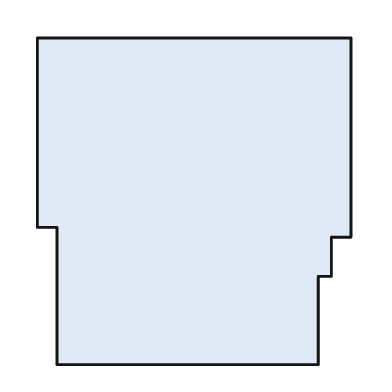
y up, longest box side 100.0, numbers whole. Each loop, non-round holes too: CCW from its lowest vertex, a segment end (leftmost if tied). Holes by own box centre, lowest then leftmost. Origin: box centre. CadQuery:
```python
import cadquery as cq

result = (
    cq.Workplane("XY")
    .moveTo(-42.0, -50.0)
    .lineTo(38.0, -50.0)
    .lineTo(38.0, -23.0)
    .lineTo(42.0, -23.0)
    .lineTo(42.0, -11.0)
    .lineTo(48.0, -11.0)
    .lineTo(48.0, 50.0)
    .lineTo(-48.0, 50.0)
    .lineTo(-48.0, -8.0)
    .lineTo(-42.0, -8.0)
    .close()
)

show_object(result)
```